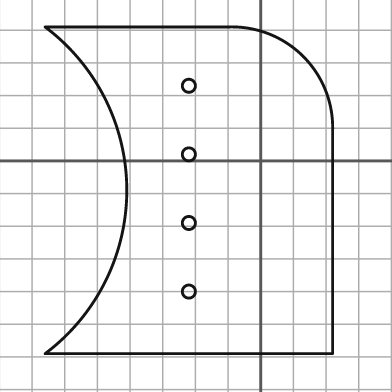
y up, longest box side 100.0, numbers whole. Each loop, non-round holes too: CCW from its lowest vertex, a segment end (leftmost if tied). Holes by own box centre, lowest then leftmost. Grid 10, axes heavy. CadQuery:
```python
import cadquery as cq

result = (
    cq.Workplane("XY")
    .moveTo(-66.0, -59.0)
    .lineTo(22.0, -59.0)
    .lineTo(22.0, 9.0)
    .threePointArc((13.0, 32.0), (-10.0, 41.0))
    .lineTo(-66.0, 41.0)
    .threePointArc((-41.0, -9.0), (-66.0, -59.0))
    .close()
    .moveTo(-22.0, -40.0)
    .circle(2.0)
    .moveTo(-22.0, -19.0)
    .circle(2.0)
    .moveTo(-22.0, 2.0)
    .circle(2.0)
    .moveTo(-22.0, 23.0)
    .circle(2.0)
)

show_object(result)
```